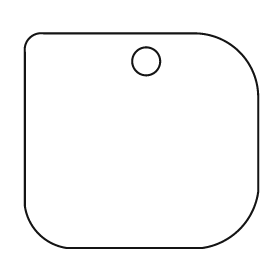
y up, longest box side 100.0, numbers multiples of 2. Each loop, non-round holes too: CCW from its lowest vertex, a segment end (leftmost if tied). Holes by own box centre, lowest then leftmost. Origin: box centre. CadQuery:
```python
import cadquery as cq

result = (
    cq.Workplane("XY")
    .moveTo(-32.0, -46.0)
    .lineTo(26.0, -46.0)
    .threePointArc((42.0, -38.0), (50.0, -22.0))
    .lineTo(50.0, 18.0)
    .threePointArc((42.0, 38.0), (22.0, 46.0))
    .lineTo(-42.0, 46.0)
    .threePointArc((-48.0, 44.0), (-50.0, 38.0))
    .lineTo(-50.0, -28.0)
    .threePointArc((-44.0, -40.0), (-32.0, -46.0))
    .close()
    .moveTo(2.0, 34.0)
    .circle(6.0)
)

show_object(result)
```